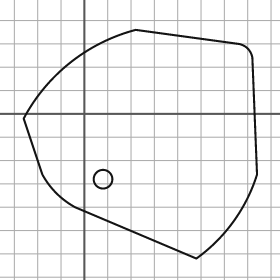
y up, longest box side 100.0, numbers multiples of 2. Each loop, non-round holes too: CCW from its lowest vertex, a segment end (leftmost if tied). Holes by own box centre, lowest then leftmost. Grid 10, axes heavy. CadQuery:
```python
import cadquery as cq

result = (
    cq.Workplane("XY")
    .moveTo(48.0, -62.0)
    .threePointArc((64.0, -46.0), (74.0, -26.0))
    .lineTo(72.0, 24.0)
    .threePointArc((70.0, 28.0), (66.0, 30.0))
    .lineTo(22.0, 36.0)
    .threePointArc((-6.0, 22.0), (-26.0, -2.0))
    .lineTo(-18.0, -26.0)
    .threePointArc((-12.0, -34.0), (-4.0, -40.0))
    .close()
    .moveTo(8.0, -28.0)
    .circle(4.0)
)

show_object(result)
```